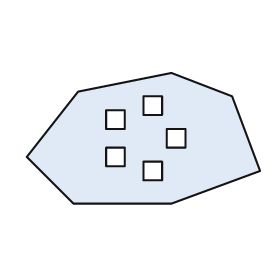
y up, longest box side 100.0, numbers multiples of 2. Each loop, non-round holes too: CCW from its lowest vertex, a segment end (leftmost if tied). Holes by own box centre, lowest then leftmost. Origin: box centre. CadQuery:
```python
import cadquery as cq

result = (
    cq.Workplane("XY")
    .moveTo(-30.0, -28.0)
    .lineTo(12.0, -28.0)
    .lineTo(50.0, -14.0)
    .lineTo(38.0, 18.0)
    .lineTo(12.0, 28.0)
    .lineTo(-28.0, 20.0)
    .lineTo(-50.0, -8.0)
    .close()
    .moveTo(0.0, -18.0)
    .lineTo(8.0, -18.0)
    .lineTo(8.0, -10.0)
    .lineTo(0.0, -10.0)
    .close()
    .moveTo(-16.0, -12.0)
    .lineTo(-8.0, -12.0)
    .lineTo(-8.0, -4.0)
    .lineTo(-16.0, -4.0)
    .close()
    .moveTo(10.0, -4.0)
    .lineTo(18.0, -4.0)
    .lineTo(18.0, 4.0)
    .lineTo(10.0, 4.0)
    .close()
    .moveTo(-16.0, 4.0)
    .lineTo(-8.0, 4.0)
    .lineTo(-8.0, 12.0)
    .lineTo(-16.0, 12.0)
    .close()
    .moveTo(0.0, 10.0)
    .lineTo(8.0, 10.0)
    .lineTo(8.0, 18.0)
    .lineTo(0.0, 18.0)
    .close()
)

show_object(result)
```